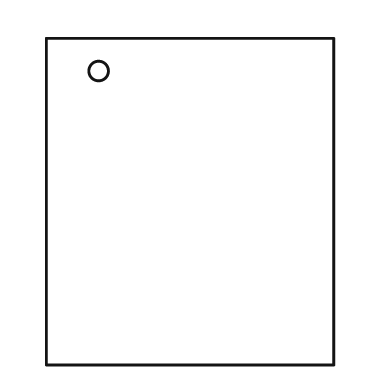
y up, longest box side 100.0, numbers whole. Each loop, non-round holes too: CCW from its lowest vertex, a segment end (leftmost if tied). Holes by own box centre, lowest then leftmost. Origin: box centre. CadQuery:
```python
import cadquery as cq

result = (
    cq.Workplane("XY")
    .moveTo(-44.0, -50.0)
    .lineTo(44.0, -50.0)
    .lineTo(44.0, 50.0)
    .lineTo(-44.0, 50.0)
    .close()
    .moveTo(-28.0, 40.0)
    .circle(3.0)
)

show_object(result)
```